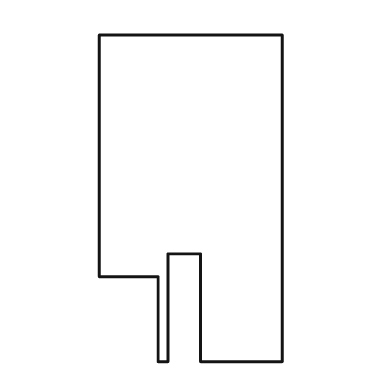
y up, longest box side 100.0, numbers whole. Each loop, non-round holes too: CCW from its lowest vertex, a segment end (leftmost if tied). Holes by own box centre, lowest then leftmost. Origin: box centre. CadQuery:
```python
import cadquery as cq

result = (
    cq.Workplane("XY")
    .moveTo(-10.0, -50.0)
    .lineTo(-7.0, -50.0)
    .lineTo(-7.0, -17.0)
    .lineTo(3.0, -17.0)
    .lineTo(3.0, -50.0)
    .lineTo(28.0, -50.0)
    .lineTo(28.0, 50.0)
    .lineTo(-28.0, 50.0)
    .lineTo(-28.0, -24.0)
    .lineTo(-10.0, -24.0)
    .close()
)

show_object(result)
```